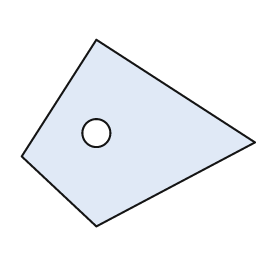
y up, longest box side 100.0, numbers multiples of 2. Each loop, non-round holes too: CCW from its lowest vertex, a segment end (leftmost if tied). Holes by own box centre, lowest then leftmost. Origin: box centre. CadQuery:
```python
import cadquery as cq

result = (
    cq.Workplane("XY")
    .moveTo(-18.0, -40.0)
    .lineTo(50.0, -4.0)
    .lineTo(-18.0, 40.0)
    .lineTo(-50.0, -10.0)
    .close()
    .moveTo(-18.0, 0.0)
    .circle(6.0)
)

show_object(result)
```